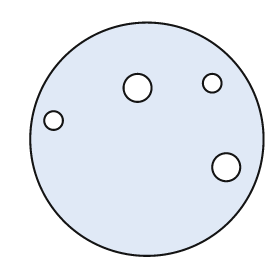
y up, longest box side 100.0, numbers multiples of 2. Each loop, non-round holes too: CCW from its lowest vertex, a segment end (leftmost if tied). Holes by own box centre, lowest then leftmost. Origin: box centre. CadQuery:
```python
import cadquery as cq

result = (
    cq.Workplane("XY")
    .moveTo(0.0, 0.0)
    .circle(50.0)
    .moveTo(34.0, -12.0)
    .circle(6.0)
    .moveTo(-40.0, 8.0)
    .circle(4.0)
    .moveTo(-4.0, 22.0)
    .circle(6.0)
    .moveTo(28.0, 24.0)
    .circle(4.0)
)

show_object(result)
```